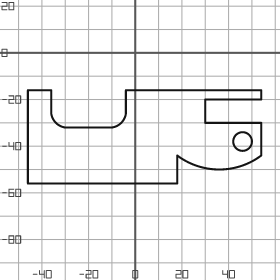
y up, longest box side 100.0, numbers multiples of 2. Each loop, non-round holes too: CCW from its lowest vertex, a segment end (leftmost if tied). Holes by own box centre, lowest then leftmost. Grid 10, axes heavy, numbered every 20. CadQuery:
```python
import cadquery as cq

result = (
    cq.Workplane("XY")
    .moveTo(-46.0, -56.0)
    .lineTo(18.0, -56.0)
    .lineTo(18.0, -44.0)
    .threePointArc((36.0, -50.0), (54.0, -44.0))
    .lineTo(54.0, -30.0)
    .lineTo(30.0, -30.0)
    .lineTo(30.0, -20.0)
    .lineTo(54.0, -20.0)
    .lineTo(54.0, -16.0)
    .lineTo(-4.0, -16.0)
    .lineTo(-4.0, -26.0)
    .threePointArc((-6.0, -30.0), (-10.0, -32.0))
    .lineTo(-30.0, -32.0)
    .threePointArc((-34.0, -30.0), (-36.0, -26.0))
    .lineTo(-36.0, -16.0)
    .lineTo(-46.0, -16.0)
    .close()
    .moveTo(46.0, -38.0)
    .circle(4.0)
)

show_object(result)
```